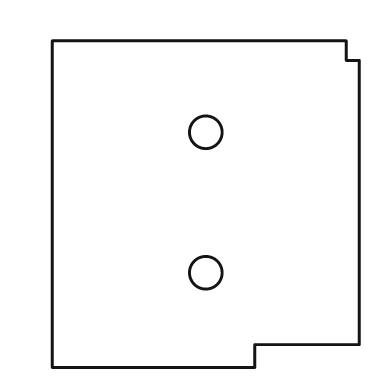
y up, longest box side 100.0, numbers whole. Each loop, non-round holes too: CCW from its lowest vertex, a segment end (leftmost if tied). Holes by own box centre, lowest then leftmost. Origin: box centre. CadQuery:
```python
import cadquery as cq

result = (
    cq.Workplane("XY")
    .moveTo(-47.0, -50.0)
    .lineTo(15.0, -50.0)
    .lineTo(15.0, -43.0)
    .lineTo(47.0, -43.0)
    .lineTo(47.0, 44.0)
    .lineTo(43.0, 44.0)
    .lineTo(43.0, 50.0)
    .lineTo(-47.0, 50.0)
    .close()
    .moveTo(0.0, -21.0)
    .circle(5.0)
    .moveTo(0.0, 22.0)
    .circle(5.0)
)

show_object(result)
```